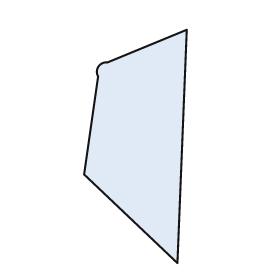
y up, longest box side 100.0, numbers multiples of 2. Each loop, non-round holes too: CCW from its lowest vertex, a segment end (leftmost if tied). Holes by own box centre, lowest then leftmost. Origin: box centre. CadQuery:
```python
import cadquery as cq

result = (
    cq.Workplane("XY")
    .moveTo(18.0, -50.0)
    .lineTo(22.0, 50.0)
    .lineTo(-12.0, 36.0)
    .threePointArc((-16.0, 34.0), (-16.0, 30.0))
    .lineTo(-22.0, -12.0)
    .close()
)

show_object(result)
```